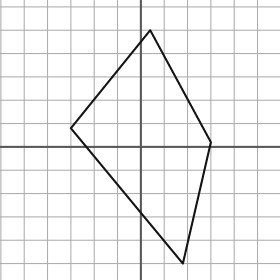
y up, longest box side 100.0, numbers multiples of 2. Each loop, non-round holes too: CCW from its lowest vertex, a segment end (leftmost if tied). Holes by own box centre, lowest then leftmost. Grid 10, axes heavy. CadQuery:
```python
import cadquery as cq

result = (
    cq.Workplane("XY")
    .moveTo(18.0, -50.0)
    .lineTo(30.0, 2.0)
    .lineTo(4.0, 50.0)
    .lineTo(-30.0, 8.0)
    .close()
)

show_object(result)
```